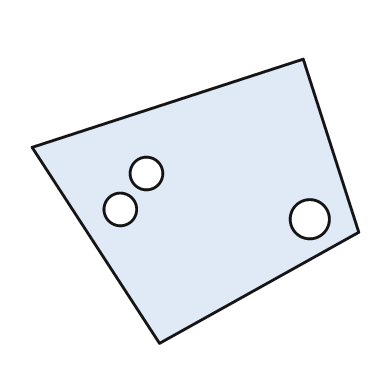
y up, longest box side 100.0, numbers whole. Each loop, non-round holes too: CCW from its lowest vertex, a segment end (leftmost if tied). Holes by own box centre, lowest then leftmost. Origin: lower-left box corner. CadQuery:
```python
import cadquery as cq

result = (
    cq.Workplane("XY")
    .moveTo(39.0, 0.0)
    .lineTo(100.0, 34.0)
    .lineTo(83.0, 87.0)
    .lineTo(0.0, 60.0)
    .close()
    .moveTo(85.0, 38.0)
    .circle(6.0)
    .moveTo(27.0, 41.0)
    .circle(5.0)
    .moveTo(35.0, 52.0)
    .circle(5.0)
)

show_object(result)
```